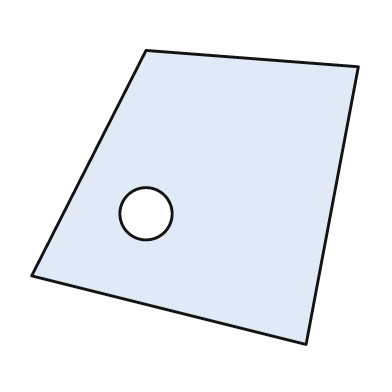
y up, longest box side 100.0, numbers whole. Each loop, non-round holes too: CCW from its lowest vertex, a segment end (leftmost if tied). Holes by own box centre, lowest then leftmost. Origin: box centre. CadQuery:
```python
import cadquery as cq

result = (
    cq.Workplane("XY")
    .moveTo(34.0, -45.0)
    .lineTo(50.0, 40.0)
    .lineTo(-15.0, 45.0)
    .lineTo(-50.0, -24.0)
    .close()
    .moveTo(-15.0, -5.0)
    .circle(8.0)
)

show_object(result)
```